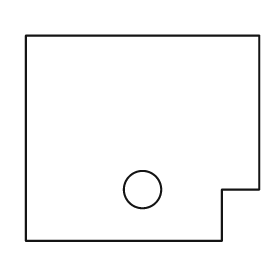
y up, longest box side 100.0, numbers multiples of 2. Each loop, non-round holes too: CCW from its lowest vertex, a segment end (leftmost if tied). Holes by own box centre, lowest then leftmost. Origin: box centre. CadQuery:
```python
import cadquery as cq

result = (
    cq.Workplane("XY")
    .moveTo(-50.0, -44.0)
    .lineTo(34.0, -44.0)
    .lineTo(34.0, -22.0)
    .lineTo(50.0, -22.0)
    .lineTo(50.0, 44.0)
    .lineTo(-50.0, 44.0)
    .close()
    .moveTo(0.0, -22.0)
    .circle(8.0)
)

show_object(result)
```